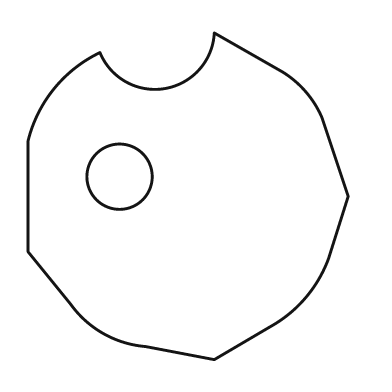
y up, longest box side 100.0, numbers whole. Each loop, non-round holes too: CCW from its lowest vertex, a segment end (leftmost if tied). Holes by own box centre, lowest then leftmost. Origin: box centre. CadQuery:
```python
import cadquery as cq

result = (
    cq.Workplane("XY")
    .moveTo(8.0, -50.0)
    .lineTo(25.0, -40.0)
    .threePointArc((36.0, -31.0), (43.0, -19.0))
    .lineTo(49.0, 0.0)
    .lineTo(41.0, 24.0)
    .threePointArc((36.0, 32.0), (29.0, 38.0))
    .lineTo(8.0, 50.0)
    .threePointArc((-7.0, 33.0), (-27.0, 44.0))
    .threePointArc((-41.0, 33.0), (-49.0, 17.0))
    .lineTo(-49.0, -17.0)
    .lineTo(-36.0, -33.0)
    .threePointArc((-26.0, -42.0), (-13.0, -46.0))
    .close()
    .moveTo(-21.0, 6.0)
    .circle(10.0)
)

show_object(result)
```